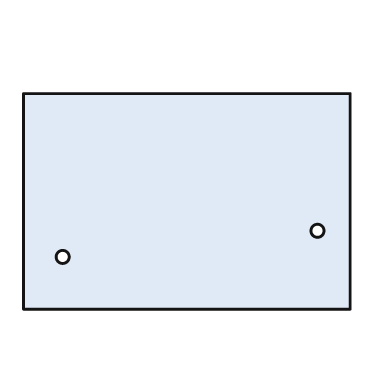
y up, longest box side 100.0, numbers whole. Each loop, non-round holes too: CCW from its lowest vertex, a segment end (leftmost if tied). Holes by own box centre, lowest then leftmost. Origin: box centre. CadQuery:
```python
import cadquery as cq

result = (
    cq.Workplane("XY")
    .moveTo(-50.0, -33.0)
    .lineTo(50.0, -33.0)
    .lineTo(50.0, 33.0)
    .lineTo(-50.0, 33.0)
    .close()
    .moveTo(-38.0, -17.0)
    .circle(2.0)
    .moveTo(40.0, -9.0)
    .circle(2.0)
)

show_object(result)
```